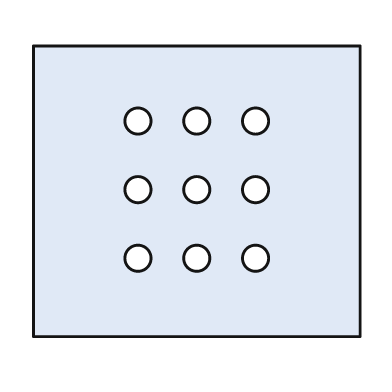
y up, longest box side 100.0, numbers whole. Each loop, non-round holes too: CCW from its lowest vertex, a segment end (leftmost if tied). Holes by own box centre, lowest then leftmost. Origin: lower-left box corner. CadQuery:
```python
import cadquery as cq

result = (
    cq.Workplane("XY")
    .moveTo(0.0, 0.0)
    .lineTo(100.0, 0.0)
    .lineTo(100.0, 89.0)
    .lineTo(0.0, 89.0)
    .close()
    .moveTo(32.0, 24.0)
    .circle(4.0)
    .moveTo(50.0, 24.0)
    .circle(4.0)
    .moveTo(68.0, 24.0)
    .circle(4.0)
    .moveTo(32.0, 45.0)
    .circle(4.0)
    .moveTo(50.0, 45.0)
    .circle(4.0)
    .moveTo(68.0, 45.0)
    .circle(4.0)
    .moveTo(32.0, 66.0)
    .circle(4.0)
    .moveTo(50.0, 66.0)
    .circle(4.0)
    .moveTo(68.0, 66.0)
    .circle(4.0)
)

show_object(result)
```